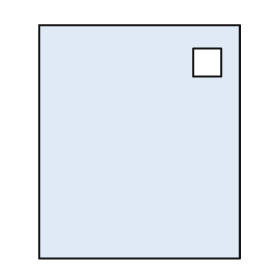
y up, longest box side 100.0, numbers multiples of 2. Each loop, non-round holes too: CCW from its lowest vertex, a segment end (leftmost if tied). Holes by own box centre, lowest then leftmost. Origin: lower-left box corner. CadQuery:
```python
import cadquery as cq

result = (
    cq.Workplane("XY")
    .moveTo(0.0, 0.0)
    .lineTo(86.0, 0.0)
    .lineTo(86.0, 100.0)
    .lineTo(0.0, 100.0)
    .close()
    .moveTo(66.0, 78.0)
    .lineTo(78.0, 78.0)
    .lineTo(78.0, 90.0)
    .lineTo(66.0, 90.0)
    .close()
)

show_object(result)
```